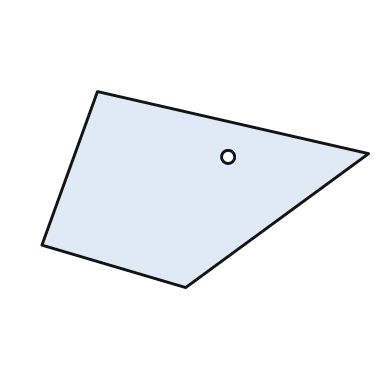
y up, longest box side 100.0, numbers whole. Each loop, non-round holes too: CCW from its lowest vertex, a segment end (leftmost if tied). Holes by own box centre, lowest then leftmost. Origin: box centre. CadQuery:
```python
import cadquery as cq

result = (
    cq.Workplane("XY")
    .moveTo(-6.0, -30.0)
    .lineTo(50.0, 11.0)
    .lineTo(-33.0, 30.0)
    .lineTo(-50.0, -17.0)
    .close()
    .moveTo(7.0, 10.0)
    .circle(2.0)
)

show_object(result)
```